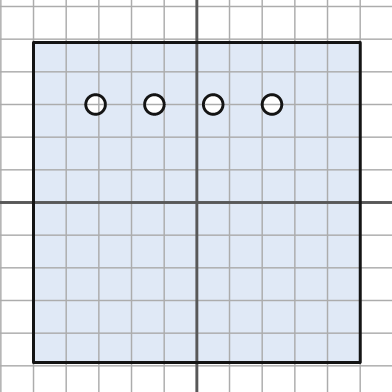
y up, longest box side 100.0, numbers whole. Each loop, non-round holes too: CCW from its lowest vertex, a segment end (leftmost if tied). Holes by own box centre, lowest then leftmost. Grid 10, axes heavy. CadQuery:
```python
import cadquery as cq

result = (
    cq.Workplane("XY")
    .moveTo(-50.0, -49.0)
    .lineTo(50.0, -49.0)
    .lineTo(50.0, 49.0)
    .lineTo(-50.0, 49.0)
    .close()
    .moveTo(-31.0, 30.0)
    .circle(3.0)
    .moveTo(-13.0, 30.0)
    .circle(3.0)
    .moveTo(5.0, 30.0)
    .circle(3.0)
    .moveTo(23.0, 30.0)
    .circle(3.0)
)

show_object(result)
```